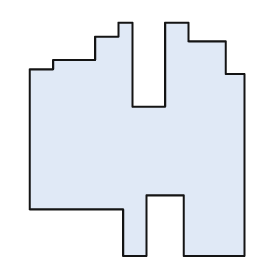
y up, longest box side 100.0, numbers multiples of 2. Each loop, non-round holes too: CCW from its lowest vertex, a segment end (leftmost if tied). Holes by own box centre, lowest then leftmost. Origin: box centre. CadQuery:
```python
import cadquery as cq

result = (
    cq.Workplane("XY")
    .moveTo(-6.0, -50.0)
    .lineTo(4.0, -50.0)
    .lineTo(4.0, -24.0)
    .lineTo(20.0, -24.0)
    .lineTo(20.0, -50.0)
    .lineTo(46.0, -50.0)
    .lineTo(46.0, 28.0)
    .lineTo(38.0, 28.0)
    .lineTo(38.0, 42.0)
    .lineTo(22.0, 42.0)
    .lineTo(22.0, 50.0)
    .lineTo(12.0, 50.0)
    .lineTo(12.0, 14.0)
    .lineTo(-2.0, 14.0)
    .lineTo(-2.0, 50.0)
    .lineTo(-8.0, 50.0)
    .lineTo(-8.0, 44.0)
    .lineTo(-18.0, 44.0)
    .lineTo(-18.0, 34.0)
    .lineTo(-36.0, 34.0)
    .lineTo(-36.0, 30.0)
    .lineTo(-46.0, 30.0)
    .lineTo(-46.0, -30.0)
    .lineTo(-6.0, -30.0)
    .close()
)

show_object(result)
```